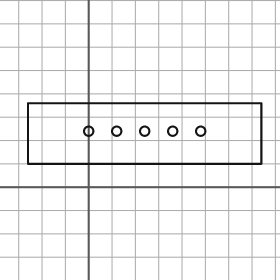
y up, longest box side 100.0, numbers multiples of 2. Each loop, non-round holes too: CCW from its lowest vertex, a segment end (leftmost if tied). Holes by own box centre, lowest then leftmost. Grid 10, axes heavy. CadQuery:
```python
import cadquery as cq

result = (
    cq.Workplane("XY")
    .moveTo(-26.0, 10.0)
    .lineTo(74.0, 10.0)
    .lineTo(74.0, 36.0)
    .lineTo(-26.0, 36.0)
    .close()
    .moveTo(0.0, 24.0)
    .circle(2.0)
    .moveTo(12.0, 24.0)
    .circle(2.0)
    .moveTo(24.0, 24.0)
    .circle(2.0)
    .moveTo(36.0, 24.0)
    .circle(2.0)
    .moveTo(48.0, 24.0)
    .circle(2.0)
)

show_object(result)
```